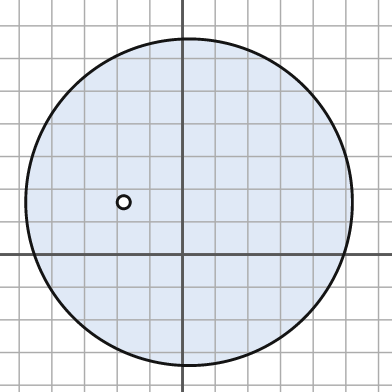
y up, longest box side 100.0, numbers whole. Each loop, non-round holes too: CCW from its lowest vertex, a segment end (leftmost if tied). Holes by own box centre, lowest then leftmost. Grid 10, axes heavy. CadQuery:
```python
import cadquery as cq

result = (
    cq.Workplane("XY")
    .moveTo(2.0, 16.0)
    .circle(50.0)
    .moveTo(-18.0, 16.0)
    .circle(2.0)
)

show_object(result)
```